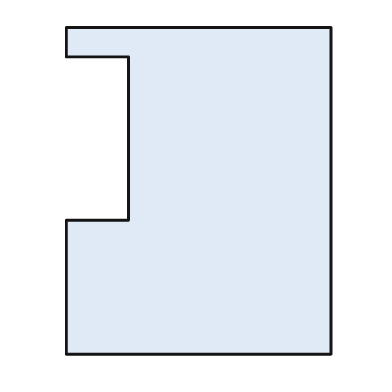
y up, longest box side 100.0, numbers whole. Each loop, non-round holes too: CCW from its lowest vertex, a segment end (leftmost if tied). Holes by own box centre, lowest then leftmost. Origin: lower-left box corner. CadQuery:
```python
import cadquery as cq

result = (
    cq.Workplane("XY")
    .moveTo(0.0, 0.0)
    .lineTo(81.0, 0.0)
    .lineTo(81.0, 100.0)
    .lineTo(0.0, 100.0)
    .lineTo(0.0, 91.0)
    .lineTo(19.0, 91.0)
    .lineTo(19.0, 41.0)
    .lineTo(0.0, 41.0)
    .close()
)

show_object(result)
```